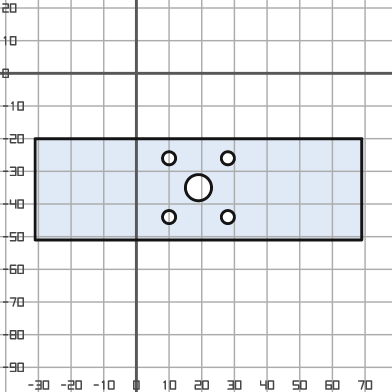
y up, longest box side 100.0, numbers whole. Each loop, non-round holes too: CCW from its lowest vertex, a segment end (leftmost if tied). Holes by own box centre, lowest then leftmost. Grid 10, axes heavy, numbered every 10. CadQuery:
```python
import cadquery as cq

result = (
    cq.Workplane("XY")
    .moveTo(-31.0, -51.0)
    .lineTo(69.0, -51.0)
    .lineTo(69.0, -20.0)
    .lineTo(-31.0, -20.0)
    .close()
    .moveTo(10.0, -44.0)
    .circle(2.0)
    .moveTo(28.0, -44.0)
    .circle(2.0)
    .moveTo(19.0, -35.0)
    .circle(4.0)
    .moveTo(10.0, -26.0)
    .circle(2.0)
    .moveTo(28.0, -26.0)
    .circle(2.0)
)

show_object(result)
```